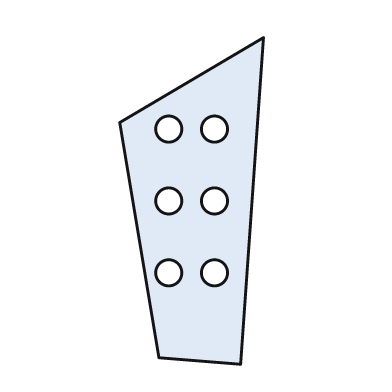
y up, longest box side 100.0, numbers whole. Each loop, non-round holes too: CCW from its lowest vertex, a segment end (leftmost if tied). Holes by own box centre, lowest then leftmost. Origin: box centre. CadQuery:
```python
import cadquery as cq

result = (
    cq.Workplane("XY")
    .moveTo(15.0, -50.0)
    .lineTo(22.0, 50.0)
    .lineTo(-22.0, 24.0)
    .lineTo(-10.0, -48.0)
    .close()
    .moveTo(-7.0, -22.0)
    .circle(4.0)
    .moveTo(7.0, -22.0)
    .circle(4.0)
    .moveTo(-7.0, 0.0)
    .circle(4.0)
    .moveTo(7.0, 0.0)
    .circle(4.0)
    .moveTo(-7.0, 22.0)
    .circle(4.0)
    .moveTo(7.0, 22.0)
    .circle(4.0)
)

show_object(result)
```